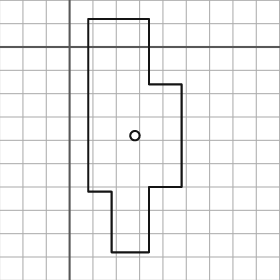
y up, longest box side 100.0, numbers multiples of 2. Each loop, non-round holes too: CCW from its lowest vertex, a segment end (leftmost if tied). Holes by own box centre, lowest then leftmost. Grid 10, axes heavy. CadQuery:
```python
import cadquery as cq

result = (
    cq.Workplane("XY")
    .moveTo(18.0, -88.0)
    .lineTo(34.0, -88.0)
    .lineTo(34.0, -60.0)
    .lineTo(48.0, -60.0)
    .lineTo(48.0, -16.0)
    .lineTo(34.0, -16.0)
    .lineTo(34.0, 12.0)
    .lineTo(8.0, 12.0)
    .lineTo(8.0, -62.0)
    .lineTo(18.0, -62.0)
    .close()
    .moveTo(28.0, -38.0)
    .circle(2.0)
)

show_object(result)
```